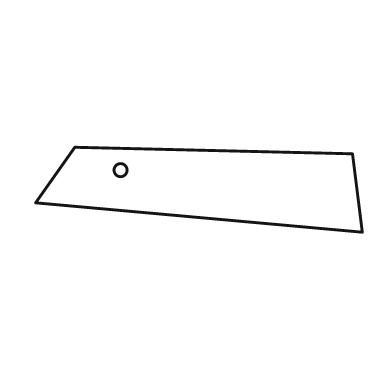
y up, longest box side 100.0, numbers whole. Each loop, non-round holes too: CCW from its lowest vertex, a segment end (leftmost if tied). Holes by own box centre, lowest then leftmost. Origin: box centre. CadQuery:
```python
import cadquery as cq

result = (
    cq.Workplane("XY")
    .moveTo(50.0, -13.0)
    .lineTo(47.0, 11.0)
    .lineTo(-38.0, 13.0)
    .lineTo(-50.0, -4.0)
    .close()
    .moveTo(-24.0, 6.0)
    .circle(2.0)
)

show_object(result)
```